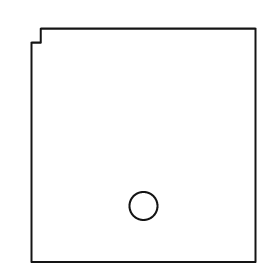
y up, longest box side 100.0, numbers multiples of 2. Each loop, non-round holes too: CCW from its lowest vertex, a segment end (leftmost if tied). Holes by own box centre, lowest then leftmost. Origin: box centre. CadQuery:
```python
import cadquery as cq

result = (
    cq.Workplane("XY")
    .moveTo(-48.0, -50.0)
    .lineTo(48.0, -50.0)
    .lineTo(48.0, 50.0)
    .lineTo(-44.0, 50.0)
    .lineTo(-44.0, 44.0)
    .lineTo(-48.0, 44.0)
    .close()
    .moveTo(0.0, -26.0)
    .circle(6.0)
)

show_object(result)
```